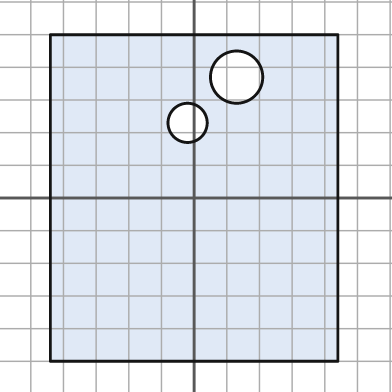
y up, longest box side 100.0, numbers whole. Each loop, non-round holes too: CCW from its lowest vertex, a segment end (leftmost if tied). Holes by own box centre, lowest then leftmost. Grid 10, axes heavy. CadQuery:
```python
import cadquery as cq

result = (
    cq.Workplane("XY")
    .moveTo(-44.0, -50.0)
    .lineTo(44.0, -50.0)
    .lineTo(44.0, 50.0)
    .lineTo(-44.0, 50.0)
    .close()
    .moveTo(-2.0, 23.0)
    .circle(6.0)
    .moveTo(13.0, 37.0)
    .circle(8.0)
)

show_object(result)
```